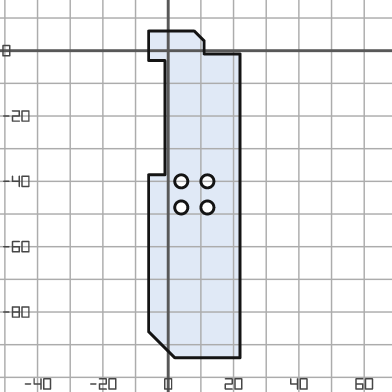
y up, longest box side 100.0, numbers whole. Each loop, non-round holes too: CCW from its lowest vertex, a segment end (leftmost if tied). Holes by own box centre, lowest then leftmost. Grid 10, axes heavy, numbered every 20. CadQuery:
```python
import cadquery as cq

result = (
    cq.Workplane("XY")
    .moveTo(2.0, -94.0)
    .lineTo(22.0, -94.0)
    .lineTo(22.0, -1.0)
    .lineTo(11.0, -1.0)
    .lineTo(11.0, 3.0)
    .lineTo(8.0, 6.0)
    .lineTo(-6.0, 6.0)
    .lineTo(-6.0, -3.0)
    .lineTo(-1.0, -3.0)
    .lineTo(-1.0, -38.0)
    .lineTo(-6.0, -38.0)
    .lineTo(-6.0, -86.0)
    .close()
    .moveTo(4.0, -48.0)
    .circle(2.0)
    .moveTo(12.0, -48.0)
    .circle(2.0)
    .moveTo(4.0, -40.0)
    .circle(2.0)
    .moveTo(12.0, -40.0)
    .circle(2.0)
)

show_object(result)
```